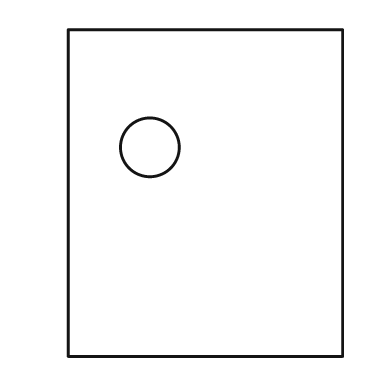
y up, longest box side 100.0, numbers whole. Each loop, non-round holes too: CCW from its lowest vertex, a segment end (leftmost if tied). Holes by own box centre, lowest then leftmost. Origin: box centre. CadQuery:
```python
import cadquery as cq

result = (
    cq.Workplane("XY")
    .moveTo(-42.0, -50.0)
    .lineTo(42.0, -50.0)
    .lineTo(42.0, 50.0)
    .lineTo(-42.0, 50.0)
    .close()
    .moveTo(-17.0, 14.0)
    .circle(9.0)
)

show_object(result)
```